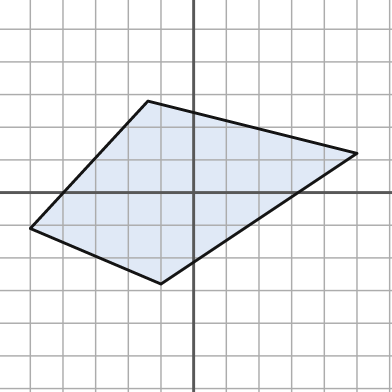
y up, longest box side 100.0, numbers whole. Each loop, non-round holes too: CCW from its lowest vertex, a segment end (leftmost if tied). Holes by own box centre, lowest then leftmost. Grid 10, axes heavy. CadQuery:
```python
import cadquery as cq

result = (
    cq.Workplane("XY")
    .moveTo(-10.0, -28.0)
    .lineTo(50.0, 12.0)
    .lineTo(-14.0, 28.0)
    .lineTo(-50.0, -11.0)
    .close()
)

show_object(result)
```